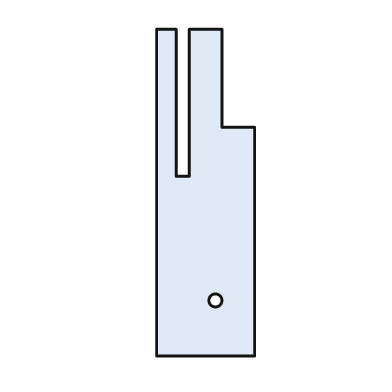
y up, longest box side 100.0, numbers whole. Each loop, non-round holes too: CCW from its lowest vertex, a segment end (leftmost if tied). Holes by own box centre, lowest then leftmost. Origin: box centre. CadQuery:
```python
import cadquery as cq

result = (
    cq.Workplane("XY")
    .moveTo(-15.0, -50.0)
    .lineTo(15.0, -50.0)
    .lineTo(15.0, 20.0)
    .lineTo(5.0, 20.0)
    .lineTo(5.0, 50.0)
    .lineTo(-5.0, 50.0)
    .lineTo(-5.0, 5.0)
    .lineTo(-9.0, 5.0)
    .lineTo(-9.0, 50.0)
    .lineTo(-15.0, 50.0)
    .close()
    .moveTo(3.0, -33.0)
    .circle(2.0)
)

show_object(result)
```